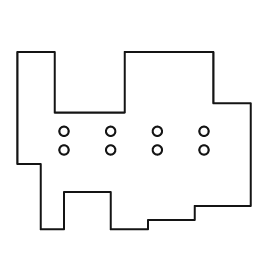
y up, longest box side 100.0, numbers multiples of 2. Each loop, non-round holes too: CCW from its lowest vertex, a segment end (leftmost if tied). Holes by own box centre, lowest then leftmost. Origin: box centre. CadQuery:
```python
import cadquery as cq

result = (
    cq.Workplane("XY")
    .moveTo(-40.0, -38.0)
    .lineTo(-30.0, -38.0)
    .lineTo(-30.0, -22.0)
    .lineTo(-10.0, -22.0)
    .lineTo(-10.0, -38.0)
    .lineTo(6.0, -38.0)
    .lineTo(6.0, -34.0)
    .lineTo(26.0, -34.0)
    .lineTo(26.0, -28.0)
    .lineTo(50.0, -28.0)
    .lineTo(50.0, 16.0)
    .lineTo(34.0, 16.0)
    .lineTo(34.0, 38.0)
    .lineTo(-4.0, 38.0)
    .lineTo(-4.0, 12.0)
    .lineTo(-34.0, 12.0)
    .lineTo(-34.0, 38.0)
    .lineTo(-50.0, 38.0)
    .lineTo(-50.0, -10.0)
    .lineTo(-40.0, -10.0)
    .close()
    .moveTo(-30.0, -4.0)
    .circle(2.0)
    .moveTo(-10.0, -4.0)
    .circle(2.0)
    .moveTo(10.0, -4.0)
    .circle(2.0)
    .moveTo(30.0, -4.0)
    .circle(2.0)
    .moveTo(-30.0, 4.0)
    .circle(2.0)
    .moveTo(-10.0, 4.0)
    .circle(2.0)
    .moveTo(10.0, 4.0)
    .circle(2.0)
    .moveTo(30.0, 4.0)
    .circle(2.0)
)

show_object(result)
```